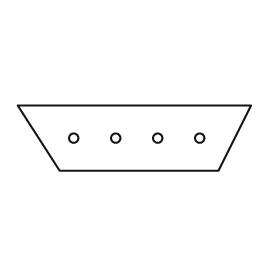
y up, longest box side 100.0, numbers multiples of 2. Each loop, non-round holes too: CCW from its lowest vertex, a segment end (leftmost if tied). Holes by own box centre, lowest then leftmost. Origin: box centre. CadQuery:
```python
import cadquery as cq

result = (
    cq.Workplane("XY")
    .moveTo(-32.0, -14.0)
    .lineTo(36.0, -14.0)
    .lineTo(50.0, 14.0)
    .lineTo(-50.0, 14.0)
    .close()
    .moveTo(-26.0, 0.0)
    .circle(2.0)
    .moveTo(-8.0, 0.0)
    .circle(2.0)
    .moveTo(10.0, 0.0)
    .circle(2.0)
    .moveTo(28.0, 0.0)
    .circle(2.0)
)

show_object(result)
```